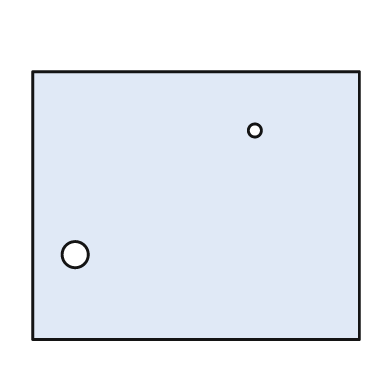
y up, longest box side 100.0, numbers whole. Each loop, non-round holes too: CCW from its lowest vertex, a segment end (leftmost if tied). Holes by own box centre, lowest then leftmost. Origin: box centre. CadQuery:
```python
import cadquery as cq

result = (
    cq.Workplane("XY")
    .moveTo(-50.0, -41.0)
    .lineTo(50.0, -41.0)
    .lineTo(50.0, 41.0)
    .lineTo(-50.0, 41.0)
    .close()
    .moveTo(-37.0, -15.0)
    .circle(4.0)
    .moveTo(18.0, 23.0)
    .circle(2.0)
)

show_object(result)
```